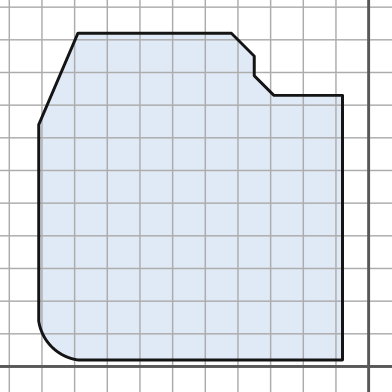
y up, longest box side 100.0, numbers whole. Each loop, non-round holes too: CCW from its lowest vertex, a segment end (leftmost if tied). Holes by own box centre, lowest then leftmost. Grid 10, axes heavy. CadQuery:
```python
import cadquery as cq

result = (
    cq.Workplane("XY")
    .moveTo(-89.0, 2.0)
    .lineTo(-8.0, 2.0)
    .lineTo(-8.0, 83.0)
    .lineTo(-29.0, 83.0)
    .lineTo(-35.0, 89.0)
    .lineTo(-35.0, 95.0)
    .lineTo(-42.0, 102.0)
    .lineTo(-89.0, 102.0)
    .lineTo(-101.0, 74.0)
    .lineTo(-101.0, 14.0)
    .threePointArc((-97.0, 6.0), (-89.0, 2.0))
    .close()
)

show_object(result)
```